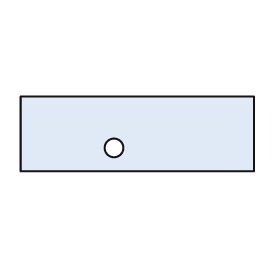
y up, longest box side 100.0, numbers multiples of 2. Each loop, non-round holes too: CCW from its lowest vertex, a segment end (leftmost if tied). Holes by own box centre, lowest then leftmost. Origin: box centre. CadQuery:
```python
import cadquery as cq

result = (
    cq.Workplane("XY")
    .moveTo(-50.0, -16.0)
    .lineTo(50.0, -16.0)
    .lineTo(50.0, 16.0)
    .lineTo(-50.0, 16.0)
    .close()
    .moveTo(-10.0, -6.0)
    .circle(4.0)
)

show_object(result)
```